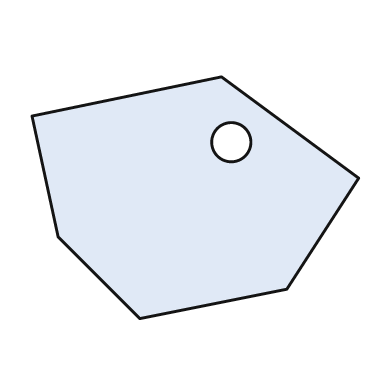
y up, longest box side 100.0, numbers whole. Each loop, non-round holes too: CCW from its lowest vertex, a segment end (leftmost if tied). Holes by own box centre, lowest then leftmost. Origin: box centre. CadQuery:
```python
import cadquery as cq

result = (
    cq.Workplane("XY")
    .moveTo(-17.0, -37.0)
    .lineTo(28.0, -28.0)
    .lineTo(50.0, 6.0)
    .lineTo(8.0, 37.0)
    .lineTo(-50.0, 25.0)
    .lineTo(-42.0, -12.0)
    .close()
    .moveTo(11.0, 17.0)
    .circle(6.0)
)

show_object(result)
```